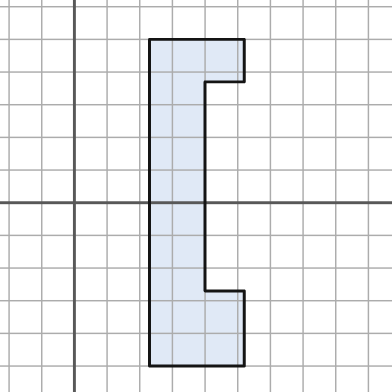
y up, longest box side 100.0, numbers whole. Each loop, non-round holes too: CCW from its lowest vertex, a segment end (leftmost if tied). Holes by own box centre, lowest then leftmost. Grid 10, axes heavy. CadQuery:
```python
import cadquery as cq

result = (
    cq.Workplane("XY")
    .moveTo(23.0, -50.0)
    .lineTo(52.0, -50.0)
    .lineTo(52.0, -27.0)
    .lineTo(40.0, -27.0)
    .lineTo(40.0, 37.0)
    .lineTo(52.0, 37.0)
    .lineTo(52.0, 50.0)
    .lineTo(23.0, 50.0)
    .close()
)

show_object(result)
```